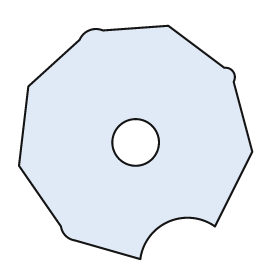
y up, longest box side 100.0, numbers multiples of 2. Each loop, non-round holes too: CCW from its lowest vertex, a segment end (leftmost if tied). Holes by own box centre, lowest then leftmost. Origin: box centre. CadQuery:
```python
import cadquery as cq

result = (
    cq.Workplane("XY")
    .moveTo(2.0, -50.0)
    .threePointArc((14.0, -34.0), (34.0, -36.0))
    .lineTo(50.0, -4.0)
    .lineTo(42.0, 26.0)
    .threePointArc((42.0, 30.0), (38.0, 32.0))
    .lineTo(14.0, 50.0)
    .lineTo(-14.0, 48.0)
    .threePointArc((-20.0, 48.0), (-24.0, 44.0))
    .lineTo(-46.0, 24.0)
    .lineTo(-50.0, -10.0)
    .lineTo(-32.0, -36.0)
    .threePointArc((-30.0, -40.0), (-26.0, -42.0))
    .close()
    .moveTo(0.0, 0.0)
    .circle(10.0)
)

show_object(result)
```